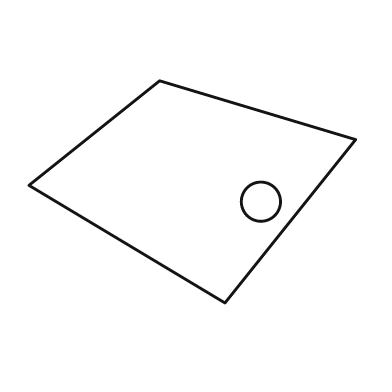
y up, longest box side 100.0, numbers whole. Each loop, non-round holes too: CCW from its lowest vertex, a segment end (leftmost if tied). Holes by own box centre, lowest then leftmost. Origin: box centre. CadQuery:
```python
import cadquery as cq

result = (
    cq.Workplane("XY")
    .moveTo(10.0, -34.0)
    .lineTo(50.0, 16.0)
    .lineTo(-10.0, 34.0)
    .lineTo(-50.0, 2.0)
    .close()
    .moveTo(21.0, -3.0)
    .circle(6.0)
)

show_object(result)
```